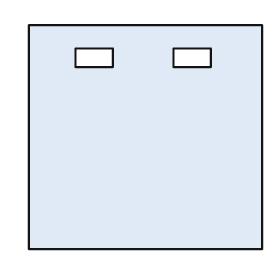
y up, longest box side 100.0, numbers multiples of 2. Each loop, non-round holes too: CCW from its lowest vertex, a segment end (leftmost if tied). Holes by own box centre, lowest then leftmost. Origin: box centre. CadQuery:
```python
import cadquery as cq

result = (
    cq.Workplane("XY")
    .moveTo(-50.0, -48.0)
    .lineTo(50.0, -48.0)
    .lineTo(50.0, 48.0)
    .lineTo(-50.0, 48.0)
    .close()
    .moveTo(-30.0, 30.0)
    .lineTo(-14.0, 30.0)
    .lineTo(-14.0, 38.0)
    .lineTo(-30.0, 38.0)
    .close()
    .moveTo(12.0, 30.0)
    .lineTo(28.0, 30.0)
    .lineTo(28.0, 38.0)
    .lineTo(12.0, 38.0)
    .close()
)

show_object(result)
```